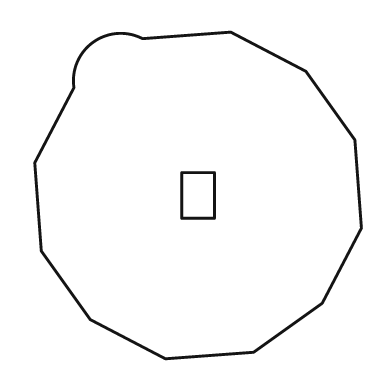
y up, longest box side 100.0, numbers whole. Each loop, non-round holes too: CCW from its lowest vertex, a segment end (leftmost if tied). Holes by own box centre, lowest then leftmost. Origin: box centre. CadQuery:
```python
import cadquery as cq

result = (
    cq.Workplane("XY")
    .moveTo(-10.0, -50.0)
    .lineTo(17.0, -48.0)
    .lineTo(38.0, -33.0)
    .lineTo(50.0, -10.0)
    .lineTo(48.0, 17.0)
    .lineTo(33.0, 38.0)
    .lineTo(10.0, 50.0)
    .lineTo(-17.0, 48.0)
    .threePointArc((-32.0, 47.0), (-38.0, 33.0))
    .lineTo(-50.0, 10.0)
    .lineTo(-48.0, -17.0)
    .lineTo(-33.0, -38.0)
    .close()
    .moveTo(-5.0, -7.0)
    .lineTo(5.0, -7.0)
    .lineTo(5.0, 7.0)
    .lineTo(-5.0, 7.0)
    .close()
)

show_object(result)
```